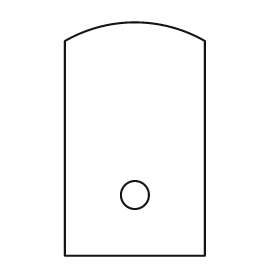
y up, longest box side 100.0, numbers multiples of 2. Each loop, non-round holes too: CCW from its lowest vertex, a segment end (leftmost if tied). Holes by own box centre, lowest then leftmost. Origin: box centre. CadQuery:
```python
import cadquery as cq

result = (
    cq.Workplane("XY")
    .moveTo(-30.0, -50.0)
    .lineTo(30.0, -50.0)
    .lineTo(30.0, 42.0)
    .threePointArc((0.0, 50.0), (-30.0, 42.0))
    .close()
    .moveTo(0.0, -24.0)
    .circle(6.0)
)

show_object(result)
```